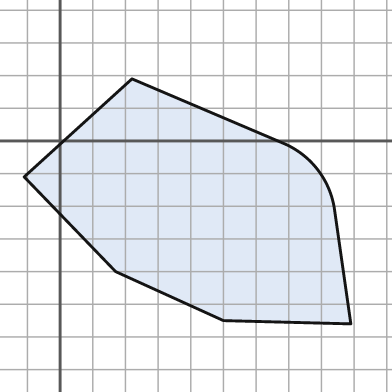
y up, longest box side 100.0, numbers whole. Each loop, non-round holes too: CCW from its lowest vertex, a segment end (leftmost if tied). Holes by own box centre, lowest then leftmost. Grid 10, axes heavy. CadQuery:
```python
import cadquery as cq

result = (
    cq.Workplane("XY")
    .moveTo(89.0, -56.0)
    .lineTo(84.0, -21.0)
    .threePointArc((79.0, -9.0), (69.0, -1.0))
    .lineTo(22.0, 19.0)
    .lineTo(-11.0, -11.0)
    .lineTo(17.0, -40.0)
    .lineTo(50.0, -55.0)
    .close()
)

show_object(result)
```